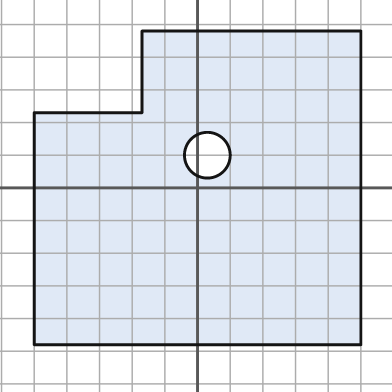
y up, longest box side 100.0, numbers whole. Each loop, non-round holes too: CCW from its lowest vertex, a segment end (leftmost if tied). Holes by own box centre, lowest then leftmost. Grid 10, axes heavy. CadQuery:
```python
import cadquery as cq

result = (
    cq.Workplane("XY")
    .moveTo(-50.0, -48.0)
    .lineTo(50.0, -48.0)
    .lineTo(50.0, 48.0)
    .lineTo(-17.0, 48.0)
    .lineTo(-17.0, 23.0)
    .lineTo(-50.0, 23.0)
    .close()
    .moveTo(3.0, 10.0)
    .circle(7.0)
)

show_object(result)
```